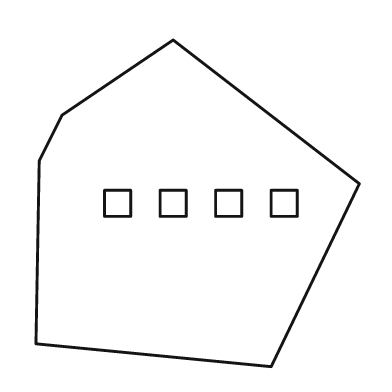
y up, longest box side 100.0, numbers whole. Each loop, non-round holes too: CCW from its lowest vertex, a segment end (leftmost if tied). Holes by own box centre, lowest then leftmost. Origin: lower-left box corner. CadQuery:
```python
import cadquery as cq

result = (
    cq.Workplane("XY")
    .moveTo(72.0, 0.0)
    .lineTo(99.0, 56.0)
    .lineTo(42.0, 100.0)
    .lineTo(8.0, 77.0)
    .lineTo(1.0, 63.0)
    .lineTo(0.0, 7.0)
    .close()
    .moveTo(21.0, 46.0)
    .lineTo(29.0, 46.0)
    .lineTo(29.0, 54.0)
    .lineTo(21.0, 54.0)
    .close()
    .moveTo(38.0, 46.0)
    .lineTo(46.0, 46.0)
    .lineTo(46.0, 54.0)
    .lineTo(38.0, 54.0)
    .close()
    .moveTo(55.0, 46.0)
    .lineTo(63.0, 46.0)
    .lineTo(63.0, 54.0)
    .lineTo(55.0, 54.0)
    .close()
    .moveTo(72.0, 46.0)
    .lineTo(80.0, 46.0)
    .lineTo(80.0, 54.0)
    .lineTo(72.0, 54.0)
    .close()
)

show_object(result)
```